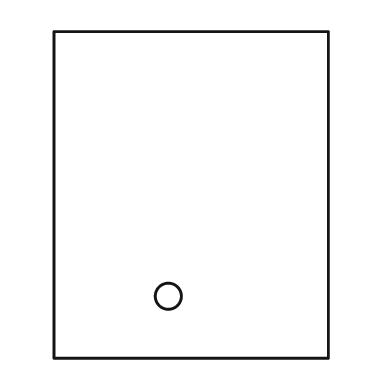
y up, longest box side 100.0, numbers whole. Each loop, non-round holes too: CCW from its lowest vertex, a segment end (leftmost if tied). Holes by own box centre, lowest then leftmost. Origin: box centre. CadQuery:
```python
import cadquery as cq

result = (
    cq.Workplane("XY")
    .moveTo(-42.0, -50.0)
    .lineTo(42.0, -50.0)
    .lineTo(42.0, 50.0)
    .lineTo(-42.0, 50.0)
    .close()
    .moveTo(-7.0, -31.0)
    .circle(4.0)
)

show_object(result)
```